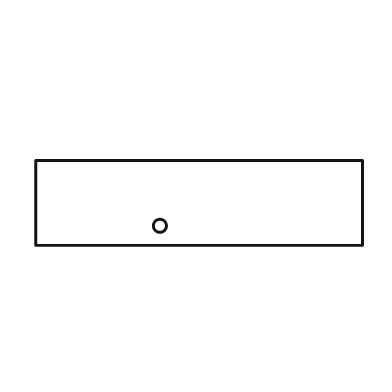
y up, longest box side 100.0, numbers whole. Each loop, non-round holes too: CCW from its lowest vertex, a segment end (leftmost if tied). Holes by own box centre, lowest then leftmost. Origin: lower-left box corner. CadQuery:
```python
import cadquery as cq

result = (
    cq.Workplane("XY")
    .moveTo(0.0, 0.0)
    .lineTo(100.0, 0.0)
    .lineTo(100.0, 26.0)
    .lineTo(0.0, 26.0)
    .close()
    .moveTo(38.0, 6.0)
    .circle(2.0)
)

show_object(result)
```